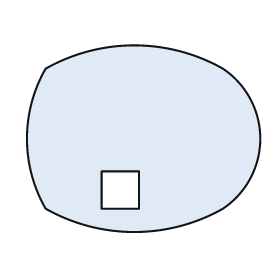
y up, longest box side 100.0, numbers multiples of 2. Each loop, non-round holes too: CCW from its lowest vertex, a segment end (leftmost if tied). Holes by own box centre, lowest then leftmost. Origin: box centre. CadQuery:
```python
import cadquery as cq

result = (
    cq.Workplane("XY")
    .moveTo(-42.0, -30.0)
    .threePointArc((-4.0, -40.0), (34.0, -30.0))
    .threePointArc((50.0, 0.0), (34.0, 30.0))
    .threePointArc((-4.0, 40.0), (-42.0, 30.0))
    .threePointArc((-50.0, 0.0), (-42.0, -30.0))
    .close()
    .moveTo(-18.0, -30.0)
    .lineTo(-2.0, -30.0)
    .lineTo(-2.0, -14.0)
    .lineTo(-18.0, -14.0)
    .close()
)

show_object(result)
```